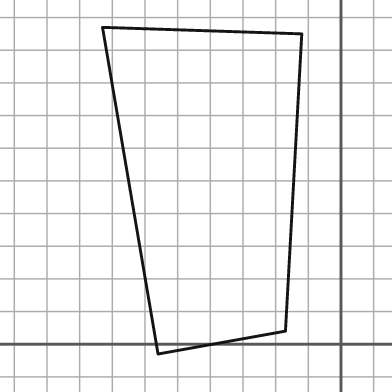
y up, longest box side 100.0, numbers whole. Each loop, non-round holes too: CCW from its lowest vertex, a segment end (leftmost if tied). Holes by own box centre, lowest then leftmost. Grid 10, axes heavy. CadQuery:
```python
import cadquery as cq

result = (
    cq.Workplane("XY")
    .moveTo(-56.0, -3.0)
    .lineTo(-17.0, 4.0)
    .lineTo(-12.0, 95.0)
    .lineTo(-73.0, 97.0)
    .close()
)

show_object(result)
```